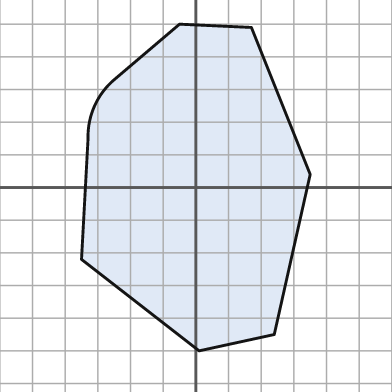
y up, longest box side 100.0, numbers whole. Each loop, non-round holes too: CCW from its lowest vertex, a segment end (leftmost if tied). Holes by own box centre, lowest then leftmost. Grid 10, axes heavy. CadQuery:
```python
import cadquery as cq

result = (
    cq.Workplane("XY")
    .moveTo(1.0, -50.0)
    .lineTo(24.0, -45.0)
    .lineTo(35.0, 4.0)
    .lineTo(17.0, 49.0)
    .lineTo(-5.0, 50.0)
    .lineTo(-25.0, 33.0)
    .threePointArc((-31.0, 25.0), (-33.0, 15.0))
    .lineTo(-35.0, -22.0)
    .close()
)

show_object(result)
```